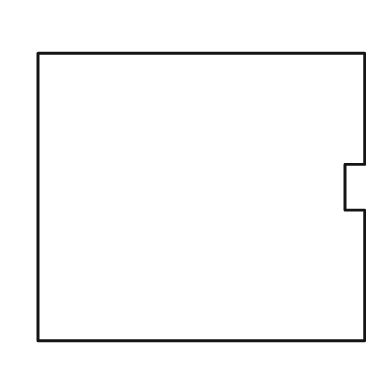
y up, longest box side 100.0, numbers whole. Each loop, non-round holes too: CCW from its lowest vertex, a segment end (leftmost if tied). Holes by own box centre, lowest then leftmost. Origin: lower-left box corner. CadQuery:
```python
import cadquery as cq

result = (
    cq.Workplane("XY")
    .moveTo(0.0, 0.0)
    .lineTo(100.0, 0.0)
    .lineTo(100.0, 40.0)
    .lineTo(94.0, 40.0)
    .lineTo(94.0, 54.0)
    .lineTo(100.0, 54.0)
    .lineTo(100.0, 88.0)
    .lineTo(0.0, 88.0)
    .close()
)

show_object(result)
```